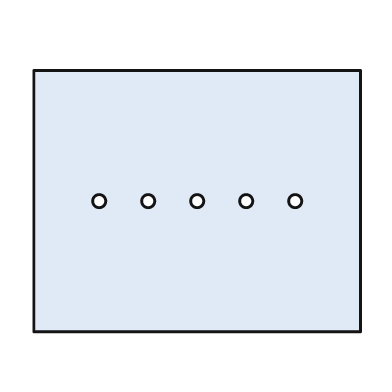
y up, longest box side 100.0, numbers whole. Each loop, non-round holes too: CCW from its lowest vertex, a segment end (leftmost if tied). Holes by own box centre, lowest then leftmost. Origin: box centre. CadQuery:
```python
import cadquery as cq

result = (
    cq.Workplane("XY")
    .moveTo(-50.0, -40.0)
    .lineTo(50.0, -40.0)
    .lineTo(50.0, 40.0)
    .lineTo(-50.0, 40.0)
    .close()
    .moveTo(-30.0, 0.0)
    .circle(2.0)
    .moveTo(-15.0, 0.0)
    .circle(2.0)
    .moveTo(0.0, 0.0)
    .circle(2.0)
    .moveTo(15.0, 0.0)
    .circle(2.0)
    .moveTo(30.0, 0.0)
    .circle(2.0)
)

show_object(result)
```